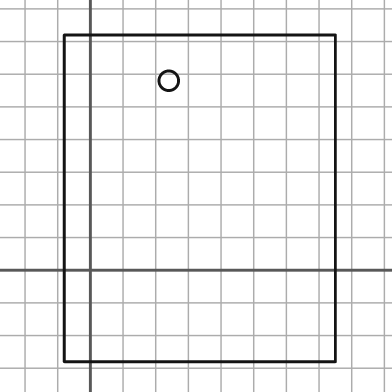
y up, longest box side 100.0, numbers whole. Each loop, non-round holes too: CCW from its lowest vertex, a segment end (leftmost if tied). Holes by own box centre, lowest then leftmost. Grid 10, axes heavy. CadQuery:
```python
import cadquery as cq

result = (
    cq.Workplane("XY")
    .moveTo(-8.0, -28.0)
    .lineTo(75.0, -28.0)
    .lineTo(75.0, 72.0)
    .lineTo(-8.0, 72.0)
    .close()
    .moveTo(24.0, 58.0)
    .circle(3.0)
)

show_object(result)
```